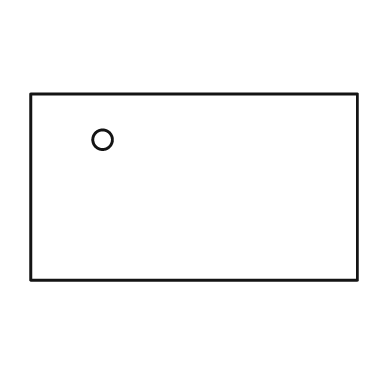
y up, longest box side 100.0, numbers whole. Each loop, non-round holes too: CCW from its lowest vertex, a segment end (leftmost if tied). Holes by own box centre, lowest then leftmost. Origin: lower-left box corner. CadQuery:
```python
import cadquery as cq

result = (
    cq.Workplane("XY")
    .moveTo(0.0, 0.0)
    .lineTo(100.0, 0.0)
    .lineTo(100.0, 57.0)
    .lineTo(0.0, 57.0)
    .close()
    .moveTo(22.0, 43.0)
    .circle(3.0)
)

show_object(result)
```